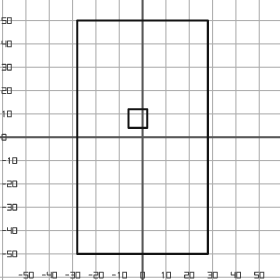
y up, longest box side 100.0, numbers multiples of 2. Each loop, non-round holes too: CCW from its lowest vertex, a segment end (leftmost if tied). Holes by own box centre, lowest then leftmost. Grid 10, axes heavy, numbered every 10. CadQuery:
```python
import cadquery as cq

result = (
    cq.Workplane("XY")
    .moveTo(-28.0, -50.0)
    .lineTo(28.0, -50.0)
    .lineTo(28.0, 50.0)
    .lineTo(-28.0, 50.0)
    .close()
    .moveTo(-6.0, 4.0)
    .lineTo(2.0, 4.0)
    .lineTo(2.0, 12.0)
    .lineTo(-6.0, 12.0)
    .close()
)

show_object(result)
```